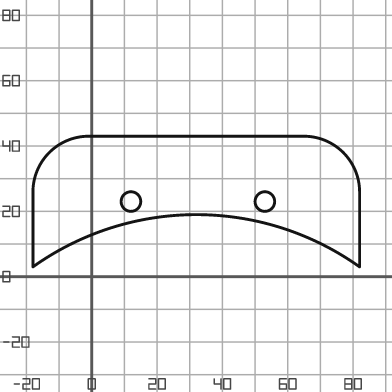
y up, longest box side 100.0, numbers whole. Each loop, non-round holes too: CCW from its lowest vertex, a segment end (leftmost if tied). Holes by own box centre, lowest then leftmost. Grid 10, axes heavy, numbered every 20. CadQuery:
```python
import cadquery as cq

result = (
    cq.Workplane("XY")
    .moveTo(-18.0, 3.0)
    .threePointArc((32.0, 19.0), (82.0, 3.0))
    .lineTo(82.0, 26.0)
    .threePointArc((77.0, 38.0), (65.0, 43.0))
    .lineTo(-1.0, 43.0)
    .threePointArc((-13.0, 38.0), (-18.0, 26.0))
    .close()
    .moveTo(12.0, 23.0)
    .circle(3.0)
    .moveTo(53.0, 23.0)
    .circle(3.0)
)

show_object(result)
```